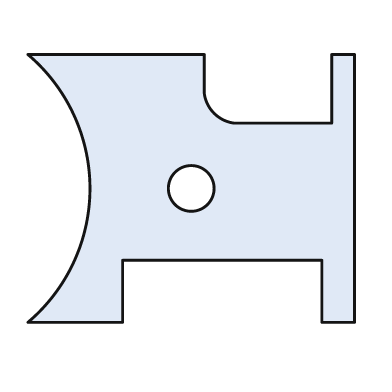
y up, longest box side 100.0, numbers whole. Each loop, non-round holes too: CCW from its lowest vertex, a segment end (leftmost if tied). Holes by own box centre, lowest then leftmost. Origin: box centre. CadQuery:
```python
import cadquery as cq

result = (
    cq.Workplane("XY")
    .moveTo(-50.0, -41.0)
    .lineTo(-21.0, -41.0)
    .lineTo(-21.0, -22.0)
    .lineTo(40.0, -22.0)
    .lineTo(40.0, -41.0)
    .lineTo(50.0, -41.0)
    .lineTo(50.0, 41.0)
    .lineTo(43.0, 41.0)
    .lineTo(43.0, 20.0)
    .lineTo(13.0, 20.0)
    .threePointArc((7.0, 23.0), (4.0, 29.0))
    .lineTo(4.0, 41.0)
    .lineTo(-50.0, 41.0)
    .threePointArc((-31.0, 0.0), (-50.0, -41.0))
    .close()
    .moveTo(0.0, 0.0)
    .circle(7.0)
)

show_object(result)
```